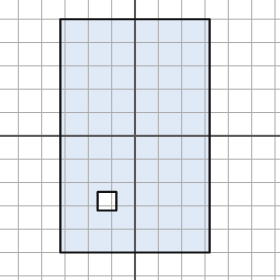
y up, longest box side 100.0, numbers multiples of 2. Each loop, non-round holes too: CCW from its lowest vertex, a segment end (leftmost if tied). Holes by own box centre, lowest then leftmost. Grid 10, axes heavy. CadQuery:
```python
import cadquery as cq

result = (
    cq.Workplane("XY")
    .moveTo(-32.0, -50.0)
    .lineTo(32.0, -50.0)
    .lineTo(32.0, 50.0)
    .lineTo(-32.0, 50.0)
    .close()
    .moveTo(-16.0, -32.0)
    .lineTo(-8.0, -32.0)
    .lineTo(-8.0, -24.0)
    .lineTo(-16.0, -24.0)
    .close()
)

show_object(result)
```